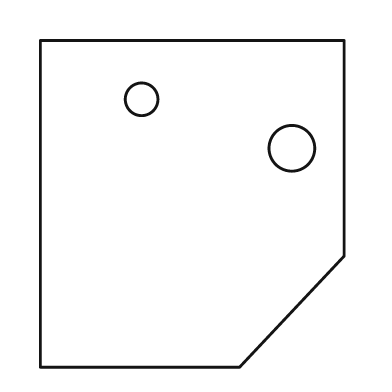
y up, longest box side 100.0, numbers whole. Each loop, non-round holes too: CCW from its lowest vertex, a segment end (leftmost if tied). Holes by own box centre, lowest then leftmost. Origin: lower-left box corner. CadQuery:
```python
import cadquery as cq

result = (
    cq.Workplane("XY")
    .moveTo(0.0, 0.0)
    .lineTo(61.0, 0.0)
    .lineTo(93.0, 34.0)
    .lineTo(93.0, 100.0)
    .lineTo(0.0, 100.0)
    .close()
    .moveTo(77.0, 67.0)
    .circle(7.0)
    .moveTo(31.0, 82.0)
    .circle(5.0)
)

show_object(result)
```